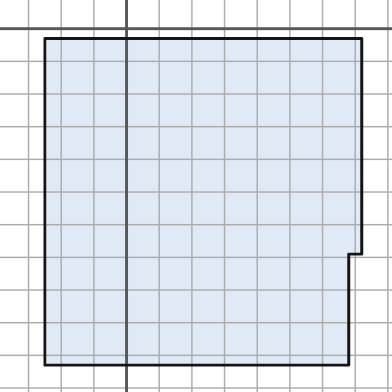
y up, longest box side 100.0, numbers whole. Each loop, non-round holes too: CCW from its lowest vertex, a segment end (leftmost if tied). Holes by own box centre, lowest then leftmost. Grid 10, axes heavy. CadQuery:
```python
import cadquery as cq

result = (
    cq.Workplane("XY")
    .moveTo(-25.0, -103.0)
    .lineTo(68.0, -103.0)
    .lineTo(68.0, -69.0)
    .lineTo(72.0, -69.0)
    .lineTo(72.0, -3.0)
    .lineTo(-25.0, -3.0)
    .close()
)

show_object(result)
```